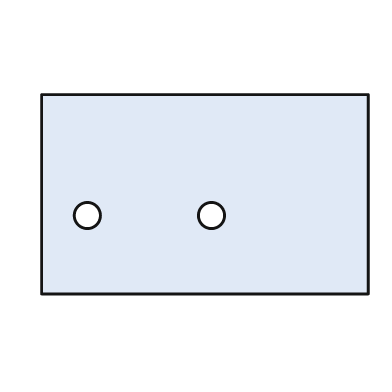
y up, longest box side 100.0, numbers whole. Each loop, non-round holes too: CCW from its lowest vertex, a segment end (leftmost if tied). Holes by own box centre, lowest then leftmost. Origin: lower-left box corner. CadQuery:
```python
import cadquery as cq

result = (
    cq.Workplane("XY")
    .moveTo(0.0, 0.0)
    .lineTo(100.0, 0.0)
    .lineTo(100.0, 61.0)
    .lineTo(0.0, 61.0)
    .close()
    .moveTo(14.0, 24.0)
    .circle(4.0)
    .moveTo(52.0, 24.0)
    .circle(4.0)
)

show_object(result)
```